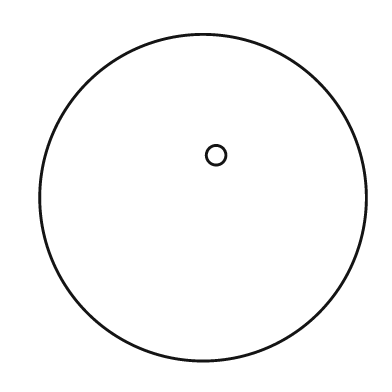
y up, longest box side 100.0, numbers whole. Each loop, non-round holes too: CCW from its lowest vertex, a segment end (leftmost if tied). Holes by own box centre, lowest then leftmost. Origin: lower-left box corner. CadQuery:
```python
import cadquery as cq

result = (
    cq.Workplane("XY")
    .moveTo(50.0, 50.0)
    .circle(50.0)
    .moveTo(54.0, 63.0)
    .circle(3.0)
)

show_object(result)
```